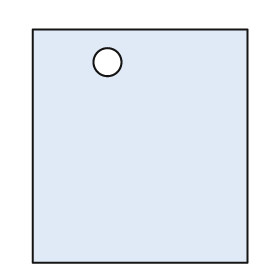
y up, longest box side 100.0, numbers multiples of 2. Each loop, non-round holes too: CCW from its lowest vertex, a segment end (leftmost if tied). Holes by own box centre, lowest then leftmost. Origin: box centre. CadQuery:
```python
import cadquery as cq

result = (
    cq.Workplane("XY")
    .moveTo(-46.0, -50.0)
    .lineTo(46.0, -50.0)
    .lineTo(46.0, 50.0)
    .lineTo(-46.0, 50.0)
    .close()
    .moveTo(-14.0, 36.0)
    .circle(6.0)
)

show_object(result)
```